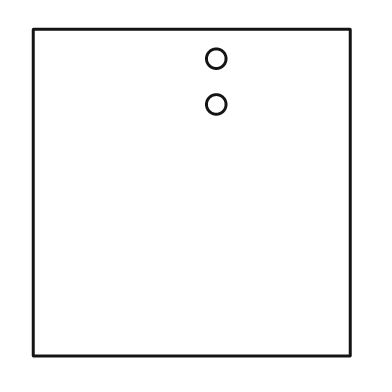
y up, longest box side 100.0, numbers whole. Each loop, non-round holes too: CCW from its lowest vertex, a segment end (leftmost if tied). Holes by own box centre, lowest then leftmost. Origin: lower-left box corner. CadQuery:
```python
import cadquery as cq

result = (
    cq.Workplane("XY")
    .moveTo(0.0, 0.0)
    .lineTo(97.0, 0.0)
    .lineTo(97.0, 100.0)
    .lineTo(0.0, 100.0)
    .close()
    .moveTo(56.0, 77.0)
    .circle(3.0)
    .moveTo(56.0, 91.0)
    .circle(3.0)
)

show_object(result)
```